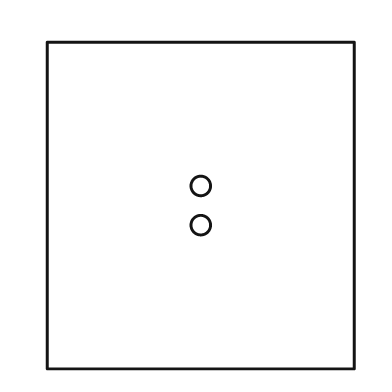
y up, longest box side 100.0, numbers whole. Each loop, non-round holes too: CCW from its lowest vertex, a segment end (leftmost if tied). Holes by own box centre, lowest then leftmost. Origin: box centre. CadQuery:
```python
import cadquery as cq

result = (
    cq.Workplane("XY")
    .moveTo(-47.0, -50.0)
    .lineTo(47.0, -50.0)
    .lineTo(47.0, 50.0)
    .lineTo(-47.0, 50.0)
    .close()
    .moveTo(0.0, -6.0)
    .circle(3.0)
    .moveTo(0.0, 6.0)
    .circle(3.0)
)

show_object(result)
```